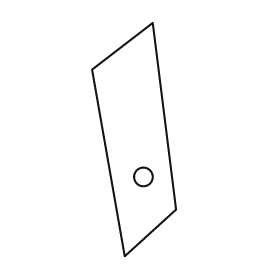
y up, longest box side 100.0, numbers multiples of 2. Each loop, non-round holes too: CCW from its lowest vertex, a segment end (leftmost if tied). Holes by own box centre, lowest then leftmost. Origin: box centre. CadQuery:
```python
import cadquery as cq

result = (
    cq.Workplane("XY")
    .moveTo(-4.0, -50.0)
    .lineTo(18.0, -30.0)
    .lineTo(8.0, 50.0)
    .lineTo(-18.0, 30.0)
    .close()
    .moveTo(4.0, -16.0)
    .circle(4.0)
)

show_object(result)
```